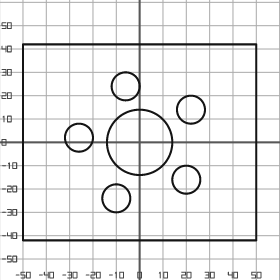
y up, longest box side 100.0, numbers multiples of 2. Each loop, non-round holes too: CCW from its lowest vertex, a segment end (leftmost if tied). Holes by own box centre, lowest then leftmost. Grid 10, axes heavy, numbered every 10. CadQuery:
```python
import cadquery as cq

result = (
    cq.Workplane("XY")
    .moveTo(-50.0, -42.0)
    .lineTo(50.0, -42.0)
    .lineTo(50.0, 42.0)
    .lineTo(-50.0, 42.0)
    .close()
    .moveTo(-10.0, -24.0)
    .circle(6.0)
    .moveTo(20.0, -16.0)
    .circle(6.0)
    .moveTo(0.0, 0.0)
    .circle(14.0)
    .moveTo(-26.0, 2.0)
    .circle(6.0)
    .moveTo(22.0, 14.0)
    .circle(6.0)
    .moveTo(-6.0, 24.0)
    .circle(6.0)
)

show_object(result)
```